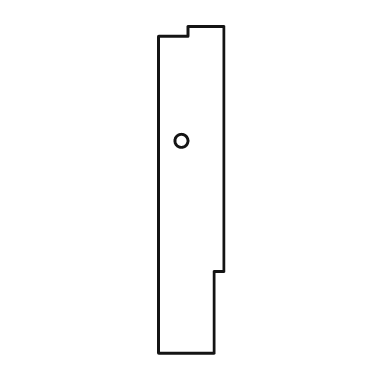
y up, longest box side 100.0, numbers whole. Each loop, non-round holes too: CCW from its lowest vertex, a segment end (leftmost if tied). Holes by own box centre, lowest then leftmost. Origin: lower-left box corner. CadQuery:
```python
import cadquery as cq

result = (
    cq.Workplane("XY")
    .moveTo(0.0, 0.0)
    .lineTo(17.0, 0.0)
    .lineTo(17.0, 25.0)
    .lineTo(20.0, 25.0)
    .lineTo(20.0, 100.0)
    .lineTo(9.0, 100.0)
    .lineTo(9.0, 97.0)
    .lineTo(0.0, 97.0)
    .close()
    .moveTo(7.0, 65.0)
    .circle(2.0)
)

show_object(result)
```